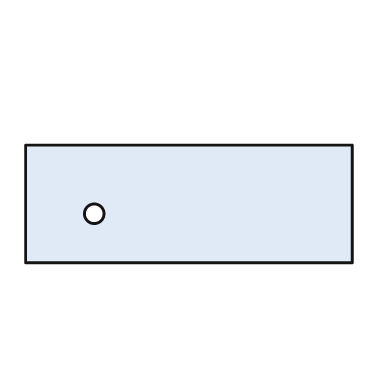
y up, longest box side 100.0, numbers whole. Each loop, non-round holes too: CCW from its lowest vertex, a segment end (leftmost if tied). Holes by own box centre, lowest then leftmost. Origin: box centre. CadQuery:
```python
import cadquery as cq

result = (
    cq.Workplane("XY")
    .moveTo(-50.0, -18.0)
    .lineTo(50.0, -18.0)
    .lineTo(50.0, 18.0)
    .lineTo(-50.0, 18.0)
    .close()
    .moveTo(-29.0, -3.0)
    .circle(3.0)
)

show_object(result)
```